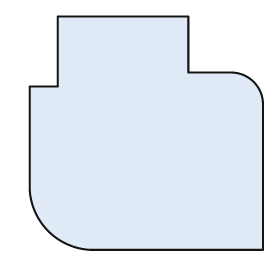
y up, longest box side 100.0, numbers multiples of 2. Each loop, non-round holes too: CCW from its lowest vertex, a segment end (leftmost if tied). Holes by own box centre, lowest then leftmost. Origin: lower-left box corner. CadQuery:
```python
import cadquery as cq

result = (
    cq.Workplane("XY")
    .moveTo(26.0, 0.0)
    .lineTo(100.0, 0.0)
    .lineTo(100.0, 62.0)
    .threePointArc((96.0, 72.0), (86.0, 76.0))
    .lineTo(68.0, 76.0)
    .lineTo(68.0, 100.0)
    .lineTo(12.0, 100.0)
    .lineTo(12.0, 70.0)
    .lineTo(0.0, 70.0)
    .lineTo(0.0, 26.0)
    .threePointArc((8.0, 8.0), (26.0, 0.0))
    .close()
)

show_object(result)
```